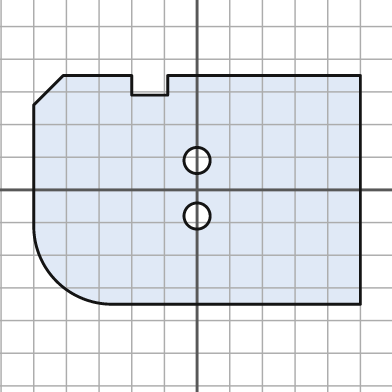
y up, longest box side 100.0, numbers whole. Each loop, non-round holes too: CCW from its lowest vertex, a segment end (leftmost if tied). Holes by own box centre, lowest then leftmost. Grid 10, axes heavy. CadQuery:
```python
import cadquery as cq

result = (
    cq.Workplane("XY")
    .moveTo(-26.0, -35.0)
    .lineTo(50.0, -35.0)
    .lineTo(50.0, 35.0)
    .lineTo(-9.0, 35.0)
    .lineTo(-9.0, 29.0)
    .lineTo(-20.0, 29.0)
    .lineTo(-20.0, 35.0)
    .lineTo(-41.0, 35.0)
    .lineTo(-50.0, 26.0)
    .lineTo(-50.0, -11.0)
    .threePointArc((-43.0, -28.0), (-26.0, -35.0))
    .close()
    .moveTo(0.0, -8.0)
    .circle(4.0)
    .moveTo(0.0, 9.0)
    .circle(4.0)
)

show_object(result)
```